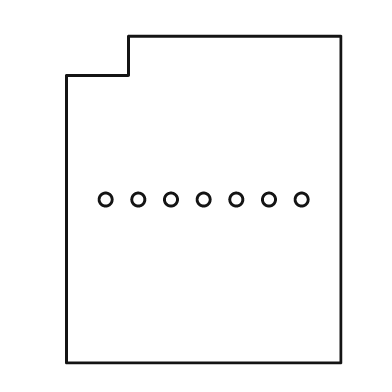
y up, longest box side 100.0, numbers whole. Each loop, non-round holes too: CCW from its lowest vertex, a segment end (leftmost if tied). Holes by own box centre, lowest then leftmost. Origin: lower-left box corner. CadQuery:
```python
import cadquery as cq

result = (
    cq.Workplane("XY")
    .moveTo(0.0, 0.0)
    .lineTo(84.0, 0.0)
    .lineTo(84.0, 100.0)
    .lineTo(19.0, 100.0)
    .lineTo(19.0, 88.0)
    .lineTo(0.0, 88.0)
    .close()
    .moveTo(12.0, 50.0)
    .circle(2.0)
    .moveTo(22.0, 50.0)
    .circle(2.0)
    .moveTo(32.0, 50.0)
    .circle(2.0)
    .moveTo(42.0, 50.0)
    .circle(2.0)
    .moveTo(52.0, 50.0)
    .circle(2.0)
    .moveTo(62.0, 50.0)
    .circle(2.0)
    .moveTo(72.0, 50.0)
    .circle(2.0)
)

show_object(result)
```